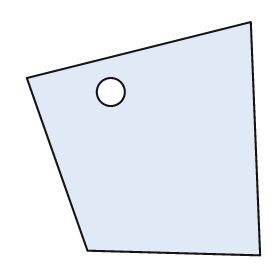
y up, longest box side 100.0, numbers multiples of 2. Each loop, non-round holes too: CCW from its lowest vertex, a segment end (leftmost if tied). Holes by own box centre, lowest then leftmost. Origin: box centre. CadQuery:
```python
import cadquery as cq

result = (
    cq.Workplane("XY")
    .moveTo(50.0, -50.0)
    .lineTo(46.0, 50.0)
    .lineTo(-50.0, 26.0)
    .lineTo(-24.0, -48.0)
    .close()
    .moveTo(-14.0, 20.0)
    .circle(6.0)
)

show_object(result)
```